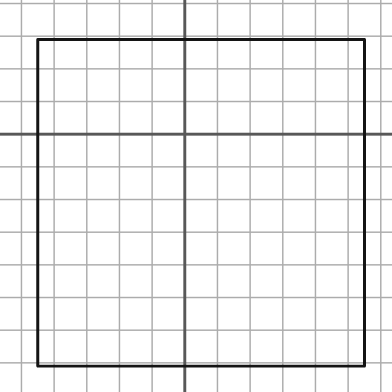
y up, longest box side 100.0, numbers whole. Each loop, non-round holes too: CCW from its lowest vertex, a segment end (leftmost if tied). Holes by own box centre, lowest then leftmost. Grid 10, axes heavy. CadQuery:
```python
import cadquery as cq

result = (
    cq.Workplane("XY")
    .moveTo(-45.0, -71.0)
    .lineTo(55.0, -71.0)
    .lineTo(55.0, 29.0)
    .lineTo(-45.0, 29.0)
    .close()
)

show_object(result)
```